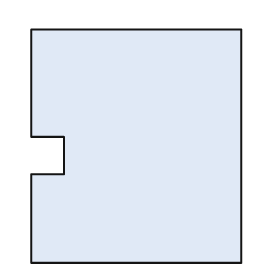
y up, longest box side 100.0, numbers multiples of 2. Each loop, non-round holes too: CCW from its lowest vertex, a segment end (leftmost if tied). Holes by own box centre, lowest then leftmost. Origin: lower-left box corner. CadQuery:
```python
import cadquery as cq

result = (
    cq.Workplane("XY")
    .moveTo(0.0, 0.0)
    .lineTo(90.0, 0.0)
    .lineTo(90.0, 100.0)
    .lineTo(0.0, 100.0)
    .lineTo(0.0, 54.0)
    .lineTo(14.0, 54.0)
    .lineTo(14.0, 38.0)
    .lineTo(0.0, 38.0)
    .close()
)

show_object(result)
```